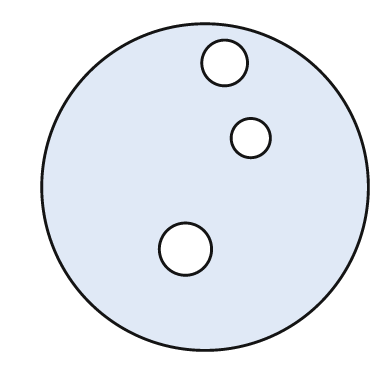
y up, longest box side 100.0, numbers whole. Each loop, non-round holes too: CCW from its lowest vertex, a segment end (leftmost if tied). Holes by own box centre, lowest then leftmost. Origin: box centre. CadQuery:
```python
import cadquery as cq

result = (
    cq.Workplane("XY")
    .moveTo(0.0, 0.0)
    .circle(50.0)
    .moveTo(-6.0, -19.0)
    .circle(8.0)
    .moveTo(14.0, 15.0)
    .circle(6.0)
    .moveTo(6.0, 38.0)
    .circle(7.0)
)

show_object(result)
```